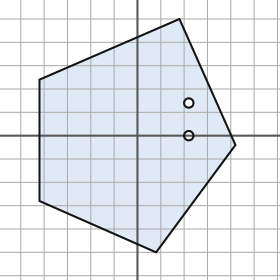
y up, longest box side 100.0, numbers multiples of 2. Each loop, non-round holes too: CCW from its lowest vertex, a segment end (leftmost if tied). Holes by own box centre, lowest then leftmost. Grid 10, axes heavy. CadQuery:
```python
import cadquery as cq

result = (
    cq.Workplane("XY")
    .moveTo(8.0, -50.0)
    .lineTo(42.0, -4.0)
    .lineTo(18.0, 50.0)
    .lineTo(-42.0, 24.0)
    .lineTo(-42.0, -28.0)
    .close()
    .moveTo(22.0, 0.0)
    .circle(2.0)
    .moveTo(22.0, 14.0)
    .circle(2.0)
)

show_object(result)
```